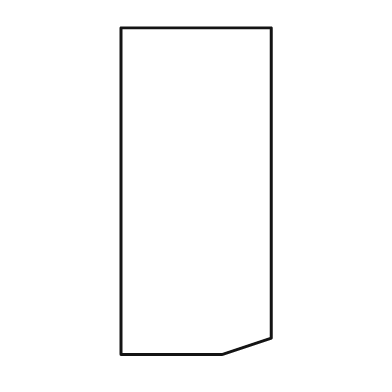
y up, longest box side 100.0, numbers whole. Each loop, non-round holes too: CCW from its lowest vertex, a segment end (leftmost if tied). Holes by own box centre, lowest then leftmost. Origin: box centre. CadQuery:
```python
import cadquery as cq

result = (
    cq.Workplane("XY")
    .moveTo(-23.0, -50.0)
    .lineTo(8.0, -50.0)
    .lineTo(23.0, -45.0)
    .lineTo(23.0, 50.0)
    .lineTo(-23.0, 50.0)
    .close()
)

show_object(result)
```